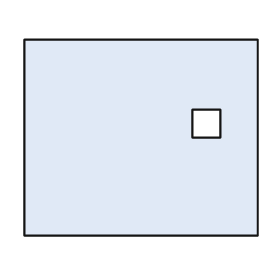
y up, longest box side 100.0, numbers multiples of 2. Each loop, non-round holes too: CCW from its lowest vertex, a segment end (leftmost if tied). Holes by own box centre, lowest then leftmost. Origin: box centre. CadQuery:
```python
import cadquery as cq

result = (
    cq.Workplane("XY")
    .moveTo(-50.0, -42.0)
    .lineTo(50.0, -42.0)
    .lineTo(50.0, 42.0)
    .lineTo(-50.0, 42.0)
    .close()
    .moveTo(22.0, 0.0)
    .lineTo(34.0, 0.0)
    .lineTo(34.0, 12.0)
    .lineTo(22.0, 12.0)
    .close()
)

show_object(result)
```